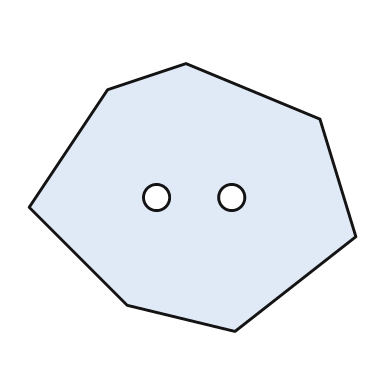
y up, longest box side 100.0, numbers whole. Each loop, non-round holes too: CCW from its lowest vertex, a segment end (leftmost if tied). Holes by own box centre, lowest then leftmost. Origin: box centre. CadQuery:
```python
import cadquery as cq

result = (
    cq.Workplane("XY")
    .moveTo(13.0, -41.0)
    .lineTo(50.0, -12.0)
    .lineTo(39.0, 24.0)
    .lineTo(-2.0, 41.0)
    .lineTo(-26.0, 33.0)
    .lineTo(-50.0, -3.0)
    .lineTo(-20.0, -33.0)
    .close()
    .moveTo(-11.0, 0.0)
    .circle(4.0)
    .moveTo(12.0, 0.0)
    .circle(4.0)
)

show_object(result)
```